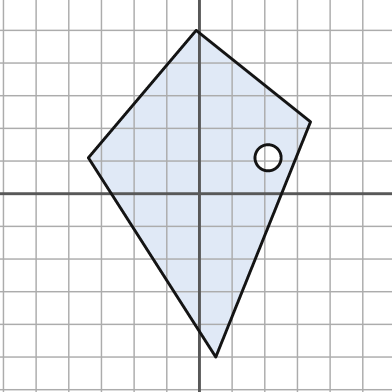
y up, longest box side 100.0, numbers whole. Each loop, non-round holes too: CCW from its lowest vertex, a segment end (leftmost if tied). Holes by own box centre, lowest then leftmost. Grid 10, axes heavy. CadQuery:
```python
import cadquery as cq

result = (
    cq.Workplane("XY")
    .moveTo(5.0, -50.0)
    .lineTo(34.0, 22.0)
    .lineTo(-1.0, 50.0)
    .lineTo(-34.0, 11.0)
    .close()
    .moveTo(21.0, 11.0)
    .circle(4.0)
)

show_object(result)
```